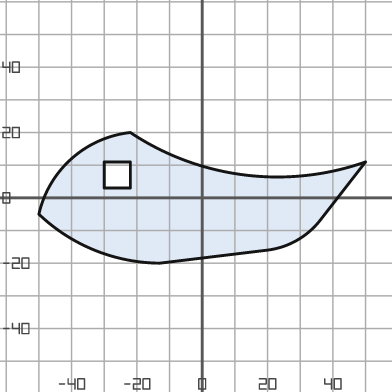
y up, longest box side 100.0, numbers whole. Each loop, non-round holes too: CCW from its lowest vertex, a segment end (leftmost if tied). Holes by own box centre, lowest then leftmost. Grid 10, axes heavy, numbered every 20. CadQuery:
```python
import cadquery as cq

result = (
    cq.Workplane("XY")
    .moveTo(-13.0, -20.0)
    .lineTo(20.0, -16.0)
    .threePointArc((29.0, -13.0), (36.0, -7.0))
    .lineTo(50.0, 11.0)
    .threePointArc((13.0, 7.0), (-22.0, 20.0))
    .threePointArc((-40.0, 12.0), (-50.0, -5.0))
    .threePointArc((-33.0, -16.0), (-13.0, -20.0))
    .close()
    .moveTo(-30.0, 3.0)
    .lineTo(-22.0, 3.0)
    .lineTo(-22.0, 11.0)
    .lineTo(-30.0, 11.0)
    .close()
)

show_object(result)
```